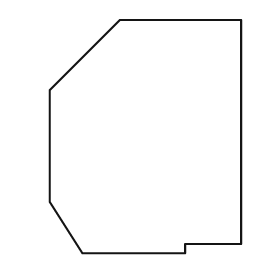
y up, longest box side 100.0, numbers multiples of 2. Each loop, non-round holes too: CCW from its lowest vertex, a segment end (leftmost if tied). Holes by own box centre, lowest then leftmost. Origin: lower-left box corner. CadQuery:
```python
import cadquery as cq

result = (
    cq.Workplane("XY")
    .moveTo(14.0, 0.0)
    .lineTo(58.0, 0.0)
    .lineTo(58.0, 4.0)
    .lineTo(82.0, 4.0)
    .lineTo(82.0, 100.0)
    .lineTo(30.0, 100.0)
    .lineTo(0.0, 70.0)
    .lineTo(0.0, 22.0)
    .close()
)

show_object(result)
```